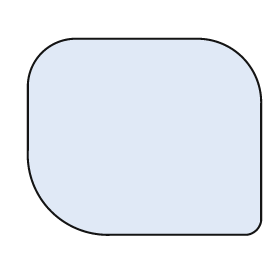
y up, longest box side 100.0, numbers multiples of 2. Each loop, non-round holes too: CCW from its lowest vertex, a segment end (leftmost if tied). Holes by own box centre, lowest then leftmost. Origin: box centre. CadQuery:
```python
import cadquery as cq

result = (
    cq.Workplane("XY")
    .moveTo(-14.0, -42.0)
    .lineTo(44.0, -42.0)
    .threePointArc((48.0, -40.0), (50.0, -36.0))
    .lineTo(50.0, 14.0)
    .threePointArc((42.0, 34.0), (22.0, 42.0))
    .lineTo(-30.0, 42.0)
    .threePointArc((-44.0, 36.0), (-50.0, 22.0))
    .lineTo(-50.0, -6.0)
    .threePointArc((-40.0, -32.0), (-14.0, -42.0))
    .close()
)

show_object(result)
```